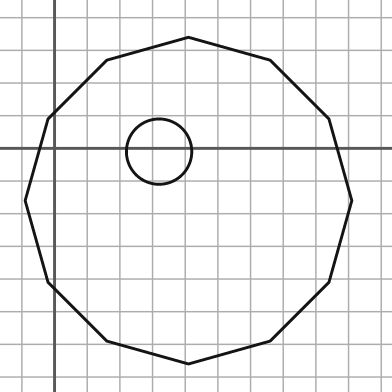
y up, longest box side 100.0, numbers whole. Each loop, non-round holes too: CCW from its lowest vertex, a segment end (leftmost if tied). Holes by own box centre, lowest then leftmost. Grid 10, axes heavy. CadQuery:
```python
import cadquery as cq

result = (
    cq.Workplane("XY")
    .moveTo(41.0, -66.0)
    .lineTo(66.0, -59.0)
    .lineTo(84.0, -41.0)
    .lineTo(91.0, -16.0)
    .lineTo(84.0, 9.0)
    .lineTo(66.0, 27.0)
    .lineTo(41.0, 34.0)
    .lineTo(16.0, 27.0)
    .lineTo(-2.0, 9.0)
    .lineTo(-9.0, -16.0)
    .lineTo(-2.0, -41.0)
    .lineTo(16.0, -59.0)
    .close()
    .moveTo(32.0, -1.0)
    .circle(10.0)
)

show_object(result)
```